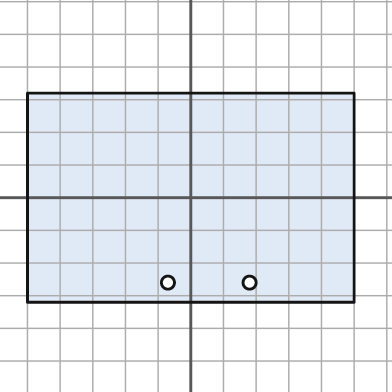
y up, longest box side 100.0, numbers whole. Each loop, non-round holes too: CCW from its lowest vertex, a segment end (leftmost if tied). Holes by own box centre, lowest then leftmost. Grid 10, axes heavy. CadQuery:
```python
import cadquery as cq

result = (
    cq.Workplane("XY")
    .moveTo(-50.0, -32.0)
    .lineTo(50.0, -32.0)
    .lineTo(50.0, 32.0)
    .lineTo(-50.0, 32.0)
    .close()
    .moveTo(-7.0, -26.0)
    .circle(2.0)
    .moveTo(18.0, -26.0)
    .circle(2.0)
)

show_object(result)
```